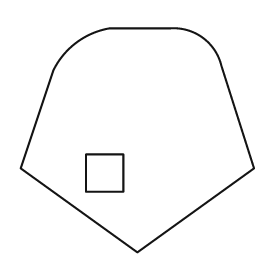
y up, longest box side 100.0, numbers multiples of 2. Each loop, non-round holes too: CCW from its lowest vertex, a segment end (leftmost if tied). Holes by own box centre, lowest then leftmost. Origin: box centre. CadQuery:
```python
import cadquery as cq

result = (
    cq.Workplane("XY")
    .moveTo(0.0, -48.0)
    .lineTo(50.0, -12.0)
    .lineTo(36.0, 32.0)
    .threePointArc((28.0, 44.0), (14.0, 48.0))
    .lineTo(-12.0, 48.0)
    .threePointArc((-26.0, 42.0), (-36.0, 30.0))
    .lineTo(-50.0, -12.0)
    .close()
    .moveTo(-22.0, -22.0)
    .lineTo(-6.0, -22.0)
    .lineTo(-6.0, -6.0)
    .lineTo(-22.0, -6.0)
    .close()
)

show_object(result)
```